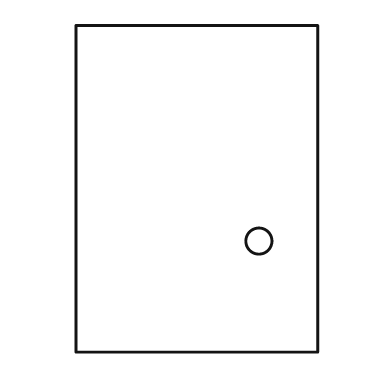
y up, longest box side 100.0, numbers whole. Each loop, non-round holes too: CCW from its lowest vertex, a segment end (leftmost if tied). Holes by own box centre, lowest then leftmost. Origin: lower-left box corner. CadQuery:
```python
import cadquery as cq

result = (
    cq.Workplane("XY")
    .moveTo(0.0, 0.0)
    .lineTo(74.0, 0.0)
    .lineTo(74.0, 100.0)
    .lineTo(0.0, 100.0)
    .close()
    .moveTo(56.0, 34.0)
    .circle(4.0)
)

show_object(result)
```